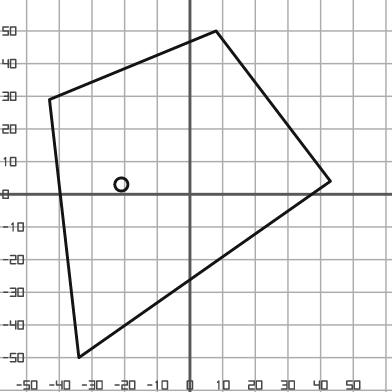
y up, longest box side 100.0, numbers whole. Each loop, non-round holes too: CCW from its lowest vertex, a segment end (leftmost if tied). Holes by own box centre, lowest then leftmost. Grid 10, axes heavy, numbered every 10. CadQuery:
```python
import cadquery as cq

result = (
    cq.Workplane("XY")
    .moveTo(-34.0, -50.0)
    .lineTo(43.0, 4.0)
    .lineTo(8.0, 50.0)
    .lineTo(-43.0, 29.0)
    .close()
    .moveTo(-21.0, 3.0)
    .circle(2.0)
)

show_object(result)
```